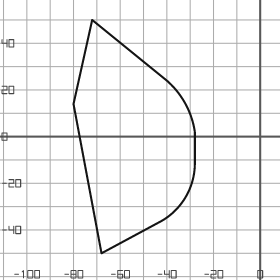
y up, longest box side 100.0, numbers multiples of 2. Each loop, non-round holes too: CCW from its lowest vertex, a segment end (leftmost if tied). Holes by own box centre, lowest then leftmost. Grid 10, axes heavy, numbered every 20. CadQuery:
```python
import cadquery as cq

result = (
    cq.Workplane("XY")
    .moveTo(-68.0, -50.0)
    .lineTo(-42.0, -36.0)
    .threePointArc((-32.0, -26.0), (-28.0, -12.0))
    .lineTo(-28.0, 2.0)
    .threePointArc((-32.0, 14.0), (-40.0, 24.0))
    .lineTo(-72.0, 50.0)
    .lineTo(-80.0, 14.0)
    .close()
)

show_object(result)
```